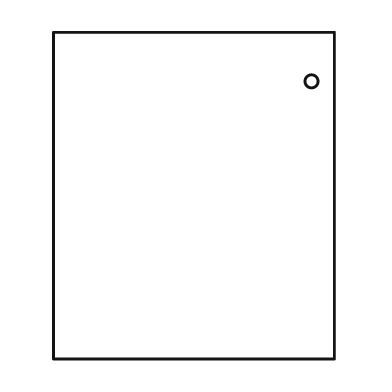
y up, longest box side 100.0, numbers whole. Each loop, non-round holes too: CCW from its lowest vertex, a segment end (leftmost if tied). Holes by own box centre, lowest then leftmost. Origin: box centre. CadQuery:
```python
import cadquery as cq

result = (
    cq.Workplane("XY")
    .moveTo(-43.0, -50.0)
    .lineTo(43.0, -50.0)
    .lineTo(43.0, 50.0)
    .lineTo(-43.0, 50.0)
    .close()
    .moveTo(36.0, 35.0)
    .circle(2.0)
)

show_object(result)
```